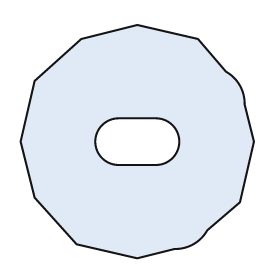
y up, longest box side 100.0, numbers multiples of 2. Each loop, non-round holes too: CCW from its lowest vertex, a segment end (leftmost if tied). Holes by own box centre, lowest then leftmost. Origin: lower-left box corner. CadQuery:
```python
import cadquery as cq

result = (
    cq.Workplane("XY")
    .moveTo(50.0, 0.0)
    .lineTo(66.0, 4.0)
    .threePointArc((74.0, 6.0), (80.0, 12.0))
    .lineTo(94.0, 24.0)
    .lineTo(100.0, 50.0)
    .lineTo(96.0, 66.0)
    .threePointArc((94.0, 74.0), (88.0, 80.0))
    .lineTo(76.0, 94.0)
    .lineTo(50.0, 100.0)
    .lineTo(26.0, 94.0)
    .lineTo(6.0, 76.0)
    .lineTo(0.0, 50.0)
    .lineTo(6.0, 26.0)
    .lineTo(24.0, 6.0)
    .close()
    .moveTo(42.0, 40.0)
    .lineTo(58.0, 40.0)
    .threePointArc((68.0, 50.0), (58.0, 60.0))
    .lineTo(42.0, 60.0)
    .threePointArc((32.0, 50.0), (42.0, 40.0))
    .close()
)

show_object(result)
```